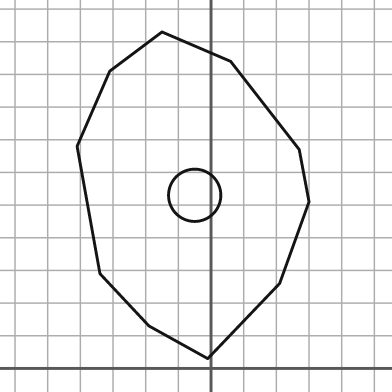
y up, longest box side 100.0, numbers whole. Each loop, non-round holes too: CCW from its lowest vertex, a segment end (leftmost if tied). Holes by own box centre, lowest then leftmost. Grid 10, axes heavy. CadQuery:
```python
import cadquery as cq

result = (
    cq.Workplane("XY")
    .moveTo(-1.0, 3.0)
    .lineTo(21.0, 26.0)
    .lineTo(30.0, 51.0)
    .lineTo(27.0, 67.0)
    .lineTo(6.0, 94.0)
    .lineTo(-15.0, 103.0)
    .lineTo(-31.0, 91.0)
    .lineTo(-41.0, 68.0)
    .lineTo(-34.0, 29.0)
    .lineTo(-19.0, 13.0)
    .close()
    .moveTo(-5.0, 53.0)
    .circle(8.0)
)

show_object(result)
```